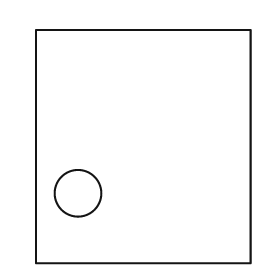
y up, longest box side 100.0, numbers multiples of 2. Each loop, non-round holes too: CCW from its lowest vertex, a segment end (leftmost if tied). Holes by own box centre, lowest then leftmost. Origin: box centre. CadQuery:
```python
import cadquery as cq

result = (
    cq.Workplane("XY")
    .moveTo(-46.0, -50.0)
    .lineTo(46.0, -50.0)
    .lineTo(46.0, 50.0)
    .lineTo(-46.0, 50.0)
    .close()
    .moveTo(-28.0, -20.0)
    .circle(10.0)
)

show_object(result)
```